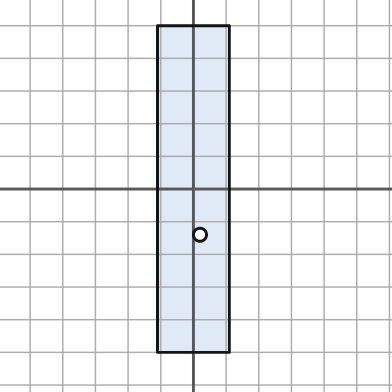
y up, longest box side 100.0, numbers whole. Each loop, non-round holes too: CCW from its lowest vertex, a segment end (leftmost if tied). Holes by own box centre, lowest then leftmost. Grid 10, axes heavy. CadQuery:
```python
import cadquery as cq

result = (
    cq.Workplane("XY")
    .moveTo(-11.0, -50.0)
    .lineTo(11.0, -50.0)
    .lineTo(11.0, 50.0)
    .lineTo(-11.0, 50.0)
    .close()
    .moveTo(2.0, -14.0)
    .circle(2.0)
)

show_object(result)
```